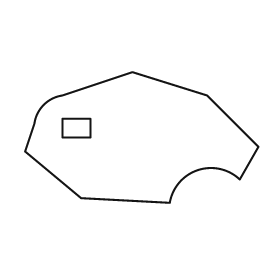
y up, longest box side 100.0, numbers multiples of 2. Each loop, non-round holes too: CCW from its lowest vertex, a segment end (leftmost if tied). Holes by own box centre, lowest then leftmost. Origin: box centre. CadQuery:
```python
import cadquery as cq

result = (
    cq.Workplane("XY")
    .moveTo(12.0, -28.0)
    .threePointArc((24.0, -14.0), (42.0, -18.0))
    .lineTo(50.0, -4.0)
    .lineTo(28.0, 18.0)
    .lineTo(-4.0, 28.0)
    .lineTo(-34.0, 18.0)
    .threePointArc((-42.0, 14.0), (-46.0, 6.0))
    .lineTo(-50.0, -6.0)
    .lineTo(-26.0, -26.0)
    .close()
    .moveTo(-34.0, 0.0)
    .lineTo(-22.0, 0.0)
    .lineTo(-22.0, 8.0)
    .lineTo(-34.0, 8.0)
    .close()
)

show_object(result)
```